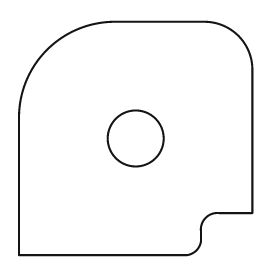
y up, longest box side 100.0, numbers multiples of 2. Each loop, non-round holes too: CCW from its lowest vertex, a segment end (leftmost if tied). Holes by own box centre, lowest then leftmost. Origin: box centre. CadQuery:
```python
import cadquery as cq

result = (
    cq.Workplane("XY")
    .moveTo(-50.0, -50.0)
    .lineTo(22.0, -50.0)
    .threePointArc((26.0, -48.0), (28.0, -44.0))
    .lineTo(28.0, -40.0)
    .threePointArc((30.0, -34.0), (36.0, -32.0))
    .lineTo(50.0, -32.0)
    .lineTo(50.0, 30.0)
    .threePointArc((44.0, 44.0), (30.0, 50.0))
    .lineTo(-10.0, 50.0)
    .threePointArc((-38.0, 38.0), (-50.0, 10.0))
    .close()
    .moveTo(0.0, 0.0)
    .circle(12.0)
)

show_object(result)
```